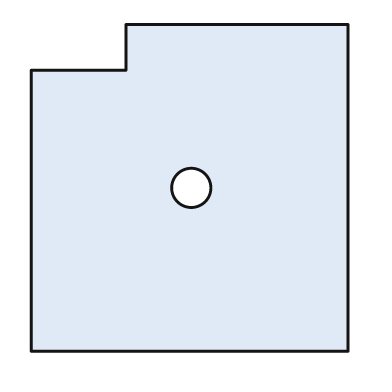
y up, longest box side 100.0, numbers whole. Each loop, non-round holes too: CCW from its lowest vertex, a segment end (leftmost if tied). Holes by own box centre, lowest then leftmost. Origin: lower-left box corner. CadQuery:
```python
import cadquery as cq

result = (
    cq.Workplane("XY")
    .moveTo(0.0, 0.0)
    .lineTo(97.0, 0.0)
    .lineTo(97.0, 100.0)
    .lineTo(29.0, 100.0)
    .lineTo(29.0, 86.0)
    .lineTo(0.0, 86.0)
    .close()
    .moveTo(49.0, 50.0)
    .circle(6.0)
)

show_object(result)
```